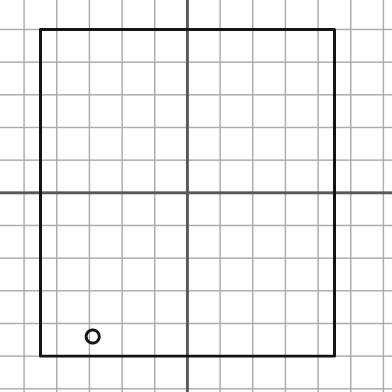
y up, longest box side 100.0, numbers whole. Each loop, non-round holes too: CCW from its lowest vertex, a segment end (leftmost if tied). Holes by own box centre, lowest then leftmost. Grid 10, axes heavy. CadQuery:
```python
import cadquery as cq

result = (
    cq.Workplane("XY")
    .moveTo(-45.0, -50.0)
    .lineTo(45.0, -50.0)
    .lineTo(45.0, 50.0)
    .lineTo(-45.0, 50.0)
    .close()
    .moveTo(-29.0, -44.0)
    .circle(2.0)
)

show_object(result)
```